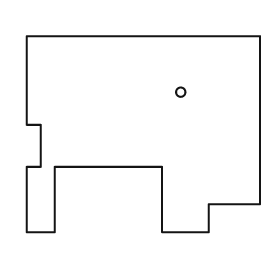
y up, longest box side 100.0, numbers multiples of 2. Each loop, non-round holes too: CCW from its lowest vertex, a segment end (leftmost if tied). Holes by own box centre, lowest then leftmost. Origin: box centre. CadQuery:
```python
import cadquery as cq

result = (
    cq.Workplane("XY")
    .moveTo(-50.0, -42.0)
    .lineTo(-38.0, -42.0)
    .lineTo(-38.0, -14.0)
    .lineTo(8.0, -14.0)
    .lineTo(8.0, -42.0)
    .lineTo(28.0, -42.0)
    .lineTo(28.0, -30.0)
    .lineTo(50.0, -30.0)
    .lineTo(50.0, 42.0)
    .lineTo(-50.0, 42.0)
    .lineTo(-50.0, 4.0)
    .lineTo(-44.0, 4.0)
    .lineTo(-44.0, -14.0)
    .lineTo(-50.0, -14.0)
    .close()
    .moveTo(16.0, 18.0)
    .circle(2.0)
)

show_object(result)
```